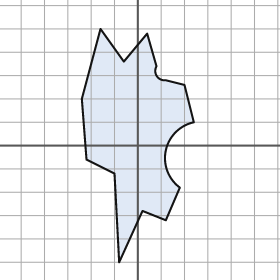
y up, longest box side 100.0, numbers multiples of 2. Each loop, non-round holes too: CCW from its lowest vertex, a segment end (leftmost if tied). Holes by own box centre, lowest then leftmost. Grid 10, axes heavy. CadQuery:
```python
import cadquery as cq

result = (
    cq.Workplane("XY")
    .moveTo(-8.0, -50.0)
    .lineTo(2.0, -28.0)
    .lineTo(12.0, -32.0)
    .lineTo(18.0, -18.0)
    .threePointArc((12.0, -2.0), (24.0, 10.0))
    .lineTo(20.0, 26.0)
    .lineTo(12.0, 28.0)
    .threePointArc((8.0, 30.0), (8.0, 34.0))
    .lineTo(4.0, 48.0)
    .lineTo(-6.0, 36.0)
    .lineTo(-16.0, 50.0)
    .lineTo(-24.0, 20.0)
    .lineTo(-22.0, -6.0)
    .lineTo(-10.0, -12.0)
    .close()
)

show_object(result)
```